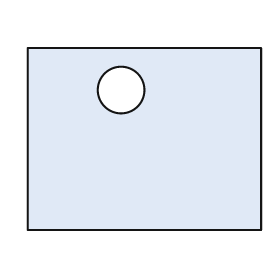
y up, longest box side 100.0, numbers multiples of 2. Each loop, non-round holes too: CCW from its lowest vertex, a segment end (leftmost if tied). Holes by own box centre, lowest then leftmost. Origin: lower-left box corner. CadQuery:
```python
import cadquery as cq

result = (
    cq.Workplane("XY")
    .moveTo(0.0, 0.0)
    .lineTo(100.0, 0.0)
    .lineTo(100.0, 78.0)
    .lineTo(0.0, 78.0)
    .close()
    .moveTo(40.0, 60.0)
    .circle(10.0)
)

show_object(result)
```